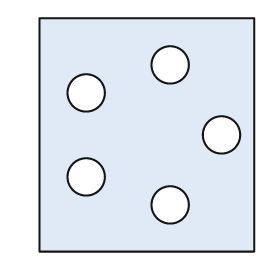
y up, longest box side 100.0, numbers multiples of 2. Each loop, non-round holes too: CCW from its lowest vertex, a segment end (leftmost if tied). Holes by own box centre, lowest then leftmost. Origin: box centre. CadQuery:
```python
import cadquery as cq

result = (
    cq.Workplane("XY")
    .moveTo(-46.0, -50.0)
    .lineTo(46.0, -50.0)
    .lineTo(46.0, 50.0)
    .lineTo(-46.0, 50.0)
    .close()
    .moveTo(10.0, -30.0)
    .circle(8.0)
    .moveTo(-26.0, -18.0)
    .circle(8.0)
    .moveTo(32.0, 0.0)
    .circle(8.0)
    .moveTo(-26.0, 18.0)
    .circle(8.0)
    .moveTo(10.0, 30.0)
    .circle(8.0)
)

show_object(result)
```